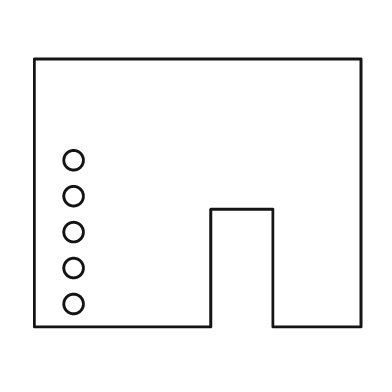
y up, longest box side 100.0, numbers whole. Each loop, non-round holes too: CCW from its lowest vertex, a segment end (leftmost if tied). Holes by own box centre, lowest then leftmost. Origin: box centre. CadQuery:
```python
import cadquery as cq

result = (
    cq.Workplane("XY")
    .moveTo(-50.0, -41.0)
    .lineTo(4.0, -41.0)
    .lineTo(4.0, -5.0)
    .lineTo(23.0, -5.0)
    .lineTo(23.0, -41.0)
    .lineTo(50.0, -41.0)
    .lineTo(50.0, 41.0)
    .lineTo(-50.0, 41.0)
    .close()
    .moveTo(-38.0, -34.0)
    .circle(3.0)
    .moveTo(-38.0, -23.0)
    .circle(3.0)
    .moveTo(-38.0, -12.0)
    .circle(3.0)
    .moveTo(-38.0, -1.0)
    .circle(3.0)
    .moveTo(-38.0, 10.0)
    .circle(3.0)
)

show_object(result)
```